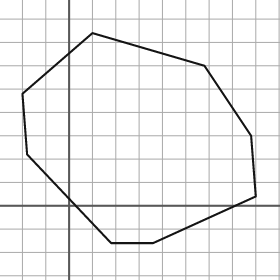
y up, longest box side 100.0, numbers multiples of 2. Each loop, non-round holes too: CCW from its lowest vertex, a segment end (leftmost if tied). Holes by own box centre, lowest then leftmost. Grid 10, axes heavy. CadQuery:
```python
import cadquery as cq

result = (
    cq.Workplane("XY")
    .moveTo(18.0, -16.0)
    .lineTo(36.0, -16.0)
    .lineTo(80.0, 4.0)
    .lineTo(78.0, 30.0)
    .lineTo(58.0, 60.0)
    .lineTo(10.0, 74.0)
    .lineTo(-20.0, 48.0)
    .lineTo(-18.0, 22.0)
    .close()
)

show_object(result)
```